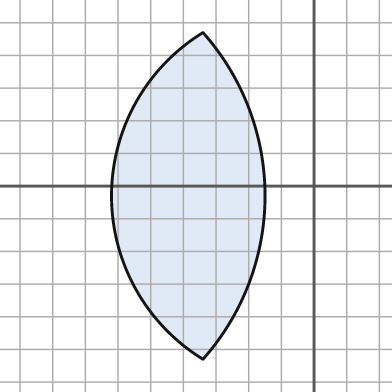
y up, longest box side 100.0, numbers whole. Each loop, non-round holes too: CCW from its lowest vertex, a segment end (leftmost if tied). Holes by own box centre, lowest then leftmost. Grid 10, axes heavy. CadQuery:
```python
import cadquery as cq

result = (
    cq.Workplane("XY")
    .moveTo(-34.0, -53.0)
    .threePointArc((-15.0, -3.0), (-34.0, 47.0))
    .threePointArc((-62.0, -3.0), (-34.0, -53.0))
    .close()
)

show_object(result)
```